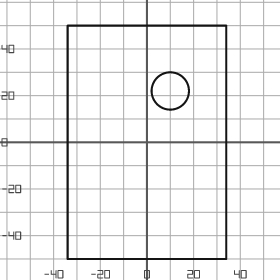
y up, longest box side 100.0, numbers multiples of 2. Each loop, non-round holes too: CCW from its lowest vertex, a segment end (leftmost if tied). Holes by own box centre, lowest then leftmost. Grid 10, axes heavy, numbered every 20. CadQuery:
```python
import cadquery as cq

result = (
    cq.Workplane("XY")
    .moveTo(-34.0, -50.0)
    .lineTo(34.0, -50.0)
    .lineTo(34.0, 50.0)
    .lineTo(-34.0, 50.0)
    .close()
    .moveTo(10.0, 22.0)
    .circle(8.0)
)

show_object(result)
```